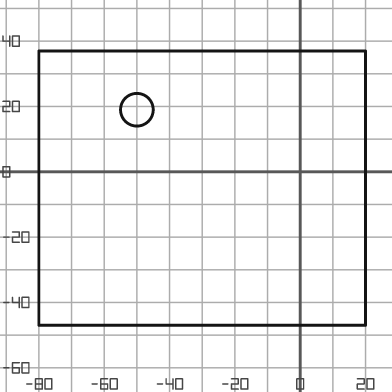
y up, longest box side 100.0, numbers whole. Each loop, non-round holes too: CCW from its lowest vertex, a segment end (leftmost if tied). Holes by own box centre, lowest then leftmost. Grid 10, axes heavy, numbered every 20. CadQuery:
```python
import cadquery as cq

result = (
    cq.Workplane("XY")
    .moveTo(-80.0, -47.0)
    .lineTo(20.0, -47.0)
    .lineTo(20.0, 37.0)
    .lineTo(-80.0, 37.0)
    .close()
    .moveTo(-50.0, 19.0)
    .circle(5.0)
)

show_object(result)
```